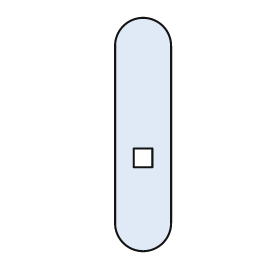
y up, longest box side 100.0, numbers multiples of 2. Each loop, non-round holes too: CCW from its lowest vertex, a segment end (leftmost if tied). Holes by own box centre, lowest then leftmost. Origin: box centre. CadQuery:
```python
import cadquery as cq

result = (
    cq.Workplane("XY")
    .moveTo(-12.0, -38.0)
    .threePointArc((0.0, -50.0), (12.0, -38.0))
    .lineTo(12.0, 38.0)
    .threePointArc((0.0, 50.0), (-12.0, 38.0))
    .close()
    .moveTo(-4.0, -14.0)
    .lineTo(4.0, -14.0)
    .lineTo(4.0, -6.0)
    .lineTo(-4.0, -6.0)
    .close()
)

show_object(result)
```